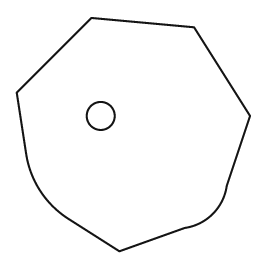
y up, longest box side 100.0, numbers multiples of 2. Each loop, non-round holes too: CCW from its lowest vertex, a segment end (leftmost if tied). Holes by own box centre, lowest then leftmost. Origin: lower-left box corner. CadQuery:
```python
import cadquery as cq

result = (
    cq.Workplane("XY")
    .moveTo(44.0, 0.0)
    .lineTo(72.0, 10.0)
    .threePointArc((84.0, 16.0), (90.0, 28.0))
    .lineTo(100.0, 58.0)
    .lineTo(76.0, 96.0)
    .lineTo(32.0, 100.0)
    .lineTo(0.0, 68.0)
    .lineTo(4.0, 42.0)
    .threePointArc((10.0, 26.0), (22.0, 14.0))
    .close()
    .moveTo(36.0, 58.0)
    .circle(6.0)
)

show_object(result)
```